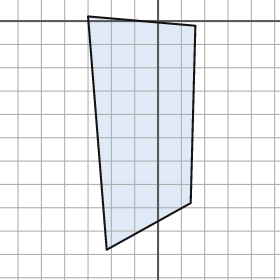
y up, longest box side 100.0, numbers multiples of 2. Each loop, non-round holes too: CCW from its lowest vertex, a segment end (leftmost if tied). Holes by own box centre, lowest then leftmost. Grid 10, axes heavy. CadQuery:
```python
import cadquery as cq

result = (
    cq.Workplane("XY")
    .moveTo(-22.0, -98.0)
    .lineTo(14.0, -78.0)
    .lineTo(16.0, -2.0)
    .lineTo(-30.0, 2.0)
    .close()
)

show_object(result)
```